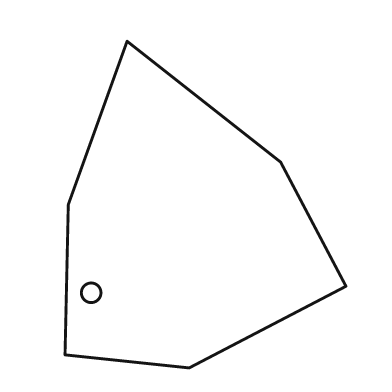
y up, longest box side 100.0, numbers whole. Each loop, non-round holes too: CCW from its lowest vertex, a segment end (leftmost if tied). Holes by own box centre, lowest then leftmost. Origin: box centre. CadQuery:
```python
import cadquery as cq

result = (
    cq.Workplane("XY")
    .moveTo(-5.0, -50.0)
    .lineTo(43.0, -25.0)
    .lineTo(23.0, 13.0)
    .lineTo(-24.0, 50.0)
    .lineTo(-42.0, 0.0)
    .lineTo(-43.0, -46.0)
    .close()
    .moveTo(-35.0, -27.0)
    .circle(3.0)
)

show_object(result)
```